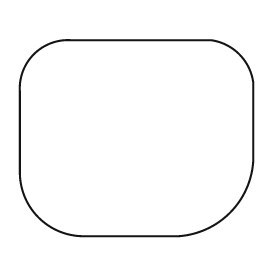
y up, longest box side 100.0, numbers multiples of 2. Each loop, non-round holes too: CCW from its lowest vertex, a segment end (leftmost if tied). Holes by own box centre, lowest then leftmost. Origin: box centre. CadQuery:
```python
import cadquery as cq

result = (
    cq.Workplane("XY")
    .moveTo(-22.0, -42.0)
    .lineTo(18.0, -42.0)
    .threePointArc((40.0, -32.0), (50.0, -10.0))
    .lineTo(50.0, 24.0)
    .threePointArc((44.0, 36.0), (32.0, 42.0))
    .lineTo(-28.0, 42.0)
    .threePointArc((-44.0, 36.0), (-50.0, 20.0))
    .lineTo(-50.0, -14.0)
    .threePointArc((-42.0, -34.0), (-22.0, -42.0))
    .close()
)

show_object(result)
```